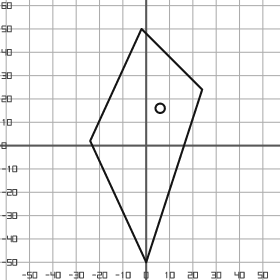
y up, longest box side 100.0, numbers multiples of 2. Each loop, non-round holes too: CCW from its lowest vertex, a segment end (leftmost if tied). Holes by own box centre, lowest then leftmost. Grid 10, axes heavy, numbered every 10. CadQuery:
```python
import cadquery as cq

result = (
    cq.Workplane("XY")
    .moveTo(0.0, -50.0)
    .lineTo(24.0, 24.0)
    .lineTo(-2.0, 50.0)
    .lineTo(-24.0, 2.0)
    .close()
    .moveTo(6.0, 16.0)
    .circle(2.0)
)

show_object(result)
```